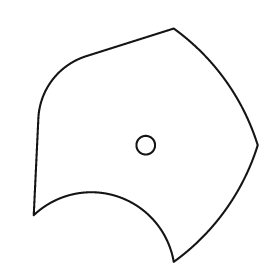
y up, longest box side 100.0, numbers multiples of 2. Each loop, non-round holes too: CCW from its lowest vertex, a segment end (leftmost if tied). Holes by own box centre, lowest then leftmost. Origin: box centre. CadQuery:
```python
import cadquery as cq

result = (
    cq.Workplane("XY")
    .moveTo(12.0, -50.0)
    .threePointArc((34.0, -28.0), (48.0, 0.0))
    .threePointArc((34.0, 28.0), (12.0, 50.0))
    .lineTo(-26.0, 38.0)
    .threePointArc((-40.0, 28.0), (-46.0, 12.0))
    .lineTo(-48.0, -30.0)
    .threePointArc((-12.0, -22.0), (12.0, -50.0))
    .close()
    .moveTo(0.0, 0.0)
    .circle(4.0)
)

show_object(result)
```